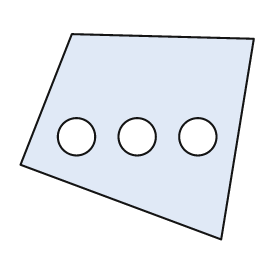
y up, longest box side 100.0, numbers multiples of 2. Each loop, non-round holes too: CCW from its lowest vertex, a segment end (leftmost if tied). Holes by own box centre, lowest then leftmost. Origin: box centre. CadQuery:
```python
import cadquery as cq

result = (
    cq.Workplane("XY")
    .moveTo(36.0, -44.0)
    .lineTo(50.0, 42.0)
    .lineTo(-28.0, 44.0)
    .lineTo(-50.0, -12.0)
    .close()
    .moveTo(-26.0, 0.0)
    .circle(8.0)
    .moveTo(0.0, 0.0)
    .circle(8.0)
    .moveTo(26.0, 0.0)
    .circle(8.0)
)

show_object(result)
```